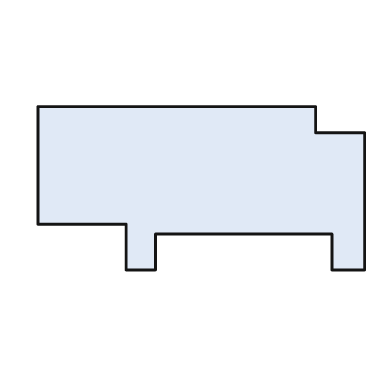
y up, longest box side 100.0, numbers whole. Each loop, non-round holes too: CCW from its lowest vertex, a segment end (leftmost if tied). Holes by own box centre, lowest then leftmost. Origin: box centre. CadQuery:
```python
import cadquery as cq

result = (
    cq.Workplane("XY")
    .moveTo(-23.0, -25.0)
    .lineTo(-14.0, -25.0)
    .lineTo(-14.0, -14.0)
    .lineTo(40.0, -14.0)
    .lineTo(40.0, -25.0)
    .lineTo(50.0, -25.0)
    .lineTo(50.0, 17.0)
    .lineTo(35.0, 17.0)
    .lineTo(35.0, 25.0)
    .lineTo(-50.0, 25.0)
    .lineTo(-50.0, -11.0)
    .lineTo(-23.0, -11.0)
    .close()
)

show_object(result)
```